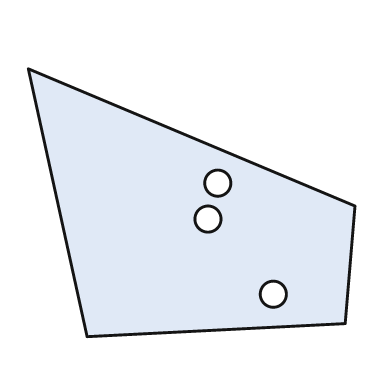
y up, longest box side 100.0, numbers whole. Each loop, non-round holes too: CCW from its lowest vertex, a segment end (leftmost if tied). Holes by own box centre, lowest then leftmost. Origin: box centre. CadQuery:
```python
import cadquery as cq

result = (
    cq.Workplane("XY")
    .moveTo(-32.0, -41.0)
    .lineTo(47.0, -37.0)
    .lineTo(50.0, -1.0)
    .lineTo(-50.0, 41.0)
    .close()
    .moveTo(25.0, -28.0)
    .circle(4.0)
    .moveTo(5.0, -5.0)
    .circle(4.0)
    .moveTo(8.0, 6.0)
    .circle(4.0)
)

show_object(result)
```